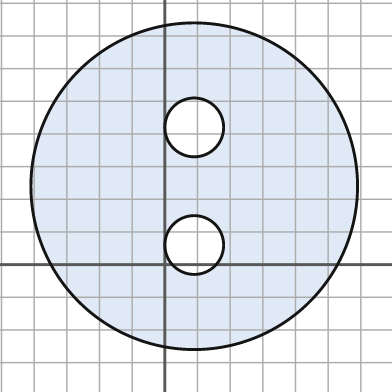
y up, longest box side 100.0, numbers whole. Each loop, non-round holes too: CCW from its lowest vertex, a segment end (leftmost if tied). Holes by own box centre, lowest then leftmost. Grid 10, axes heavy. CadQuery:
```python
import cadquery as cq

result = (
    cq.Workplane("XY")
    .moveTo(9.0, 24.0)
    .circle(50.0)
    .moveTo(9.0, 6.0)
    .circle(9.0)
    .moveTo(9.0, 42.0)
    .circle(9.0)
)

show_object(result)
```